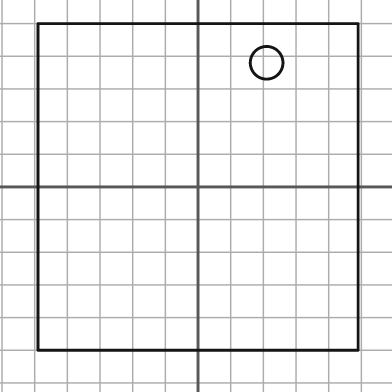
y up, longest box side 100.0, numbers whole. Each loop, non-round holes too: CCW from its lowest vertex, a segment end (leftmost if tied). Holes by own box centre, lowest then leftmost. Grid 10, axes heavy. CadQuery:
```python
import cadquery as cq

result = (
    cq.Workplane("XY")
    .moveTo(-49.0, -50.0)
    .lineTo(49.0, -50.0)
    .lineTo(49.0, 50.0)
    .lineTo(-49.0, 50.0)
    .close()
    .moveTo(21.0, 38.0)
    .circle(5.0)
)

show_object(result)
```